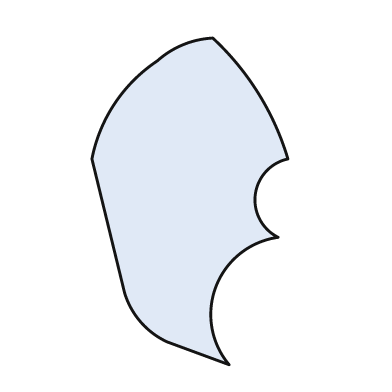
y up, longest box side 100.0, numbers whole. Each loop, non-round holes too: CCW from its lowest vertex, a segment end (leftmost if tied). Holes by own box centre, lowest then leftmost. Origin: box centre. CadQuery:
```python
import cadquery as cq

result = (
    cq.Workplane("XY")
    .moveTo(12.0, -50.0)
    .threePointArc((8.0, -26.0), (27.0, -11.0))
    .threePointArc((20.0, 2.0), (30.0, 13.0))
    .threePointArc((21.0, 33.0), (7.0, 50.0))
    .threePointArc((-2.0, 48.0), (-10.0, 43.0))
    .threePointArc((-23.0, 30.0), (-30.0, 13.0))
    .lineTo(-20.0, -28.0)
    .threePointArc((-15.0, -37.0), (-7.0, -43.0))
    .close()
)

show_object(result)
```